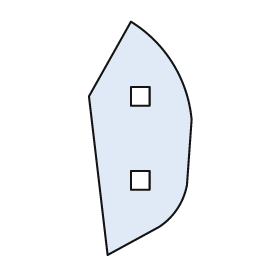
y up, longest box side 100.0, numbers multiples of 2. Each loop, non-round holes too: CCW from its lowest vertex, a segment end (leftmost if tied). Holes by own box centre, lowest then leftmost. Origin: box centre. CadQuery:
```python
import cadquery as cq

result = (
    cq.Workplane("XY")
    .moveTo(-14.0, -50.0)
    .lineTo(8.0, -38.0)
    .threePointArc((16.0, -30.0), (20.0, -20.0))
    .lineTo(22.0, 8.0)
    .threePointArc((14.0, 32.0), (-4.0, 50.0))
    .lineTo(-22.0, 18.0)
    .close()
    .moveTo(-4.0, -22.0)
    .lineTo(4.0, -22.0)
    .lineTo(4.0, -14.0)
    .lineTo(-4.0, -14.0)
    .close()
    .moveTo(-4.0, 14.0)
    .lineTo(4.0, 14.0)
    .lineTo(4.0, 22.0)
    .lineTo(-4.0, 22.0)
    .close()
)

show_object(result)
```